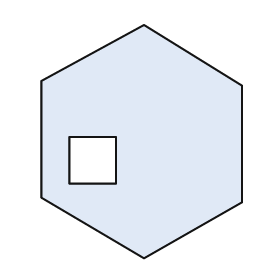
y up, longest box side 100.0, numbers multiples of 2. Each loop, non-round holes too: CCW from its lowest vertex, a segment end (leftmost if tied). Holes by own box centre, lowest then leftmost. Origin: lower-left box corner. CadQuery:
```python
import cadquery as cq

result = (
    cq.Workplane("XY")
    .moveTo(44.0, 0.0)
    .lineTo(86.0, 24.0)
    .lineTo(86.0, 74.0)
    .lineTo(44.0, 100.0)
    .lineTo(0.0, 76.0)
    .lineTo(0.0, 26.0)
    .close()
    .moveTo(12.0, 32.0)
    .lineTo(32.0, 32.0)
    .lineTo(32.0, 52.0)
    .lineTo(12.0, 52.0)
    .close()
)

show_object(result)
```